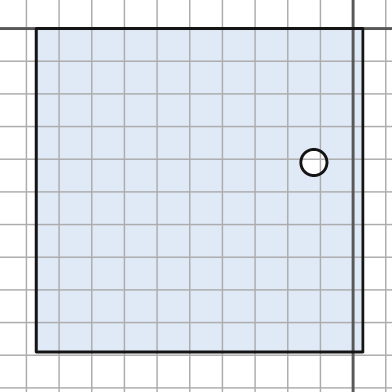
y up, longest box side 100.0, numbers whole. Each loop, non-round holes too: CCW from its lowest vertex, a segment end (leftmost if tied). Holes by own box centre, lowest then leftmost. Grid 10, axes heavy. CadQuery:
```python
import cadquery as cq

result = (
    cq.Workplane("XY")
    .moveTo(-97.0, -99.0)
    .lineTo(3.0, -99.0)
    .lineTo(3.0, 0.0)
    .lineTo(-97.0, 0.0)
    .close()
    .moveTo(-12.0, -41.0)
    .circle(4.0)
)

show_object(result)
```